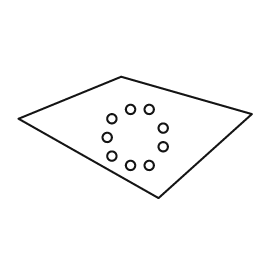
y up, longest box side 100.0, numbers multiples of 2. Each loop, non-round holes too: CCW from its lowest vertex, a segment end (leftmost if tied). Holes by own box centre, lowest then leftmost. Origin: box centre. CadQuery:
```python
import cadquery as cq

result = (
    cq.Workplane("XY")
    .moveTo(10.0, -26.0)
    .lineTo(50.0, 10.0)
    .lineTo(-6.0, 26.0)
    .lineTo(-50.0, 8.0)
    .close()
    .moveTo(-2.0, -12.0)
    .circle(2.0)
    .moveTo(6.0, -12.0)
    .circle(2.0)
    .moveTo(-10.0, -8.0)
    .circle(2.0)
    .moveTo(12.0, -4.0)
    .circle(2.0)
    .moveTo(-12.0, 0.0)
    .circle(2.0)
    .moveTo(12.0, 4.0)
    .circle(2.0)
    .moveTo(-10.0, 8.0)
    .circle(2.0)
    .moveTo(-2.0, 12.0)
    .circle(2.0)
    .moveTo(6.0, 12.0)
    .circle(2.0)
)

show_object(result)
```